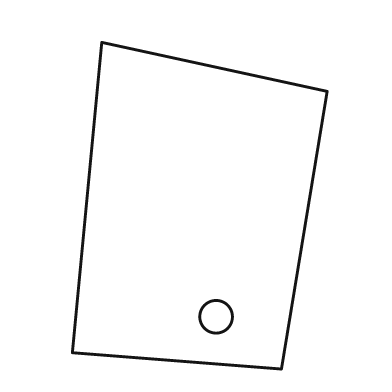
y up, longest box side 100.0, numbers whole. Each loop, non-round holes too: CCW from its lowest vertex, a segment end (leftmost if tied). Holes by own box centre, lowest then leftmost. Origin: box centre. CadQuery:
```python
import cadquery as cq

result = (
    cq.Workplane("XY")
    .moveTo(25.0, -50.0)
    .lineTo(39.0, 35.0)
    .lineTo(-30.0, 50.0)
    .lineTo(-39.0, -45.0)
    .close()
    .moveTo(5.0, -34.0)
    .circle(5.0)
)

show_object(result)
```